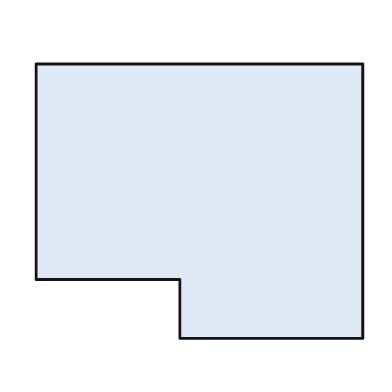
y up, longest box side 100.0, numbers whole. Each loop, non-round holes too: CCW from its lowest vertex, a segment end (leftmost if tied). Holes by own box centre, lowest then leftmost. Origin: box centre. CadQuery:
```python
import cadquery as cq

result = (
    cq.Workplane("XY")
    .moveTo(-6.0, -42.0)
    .lineTo(50.0, -42.0)
    .lineTo(50.0, 42.0)
    .lineTo(-50.0, 42.0)
    .lineTo(-50.0, -24.0)
    .lineTo(-6.0, -24.0)
    .close()
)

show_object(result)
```